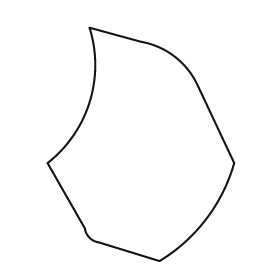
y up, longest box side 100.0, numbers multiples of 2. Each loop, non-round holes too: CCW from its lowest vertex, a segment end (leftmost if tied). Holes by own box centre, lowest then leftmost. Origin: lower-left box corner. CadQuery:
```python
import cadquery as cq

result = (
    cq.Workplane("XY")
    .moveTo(48.0, 0.0)
    .threePointArc((68.0, 18.0), (80.0, 42.0))
    .lineTo(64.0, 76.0)
    .threePointArc((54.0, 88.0), (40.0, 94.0))
    .lineTo(18.0, 100.0)
    .threePointArc((18.0, 68.0), (0.0, 42.0))
    .lineTo(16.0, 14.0)
    .threePointArc((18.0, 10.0), (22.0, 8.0))
    .close()
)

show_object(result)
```